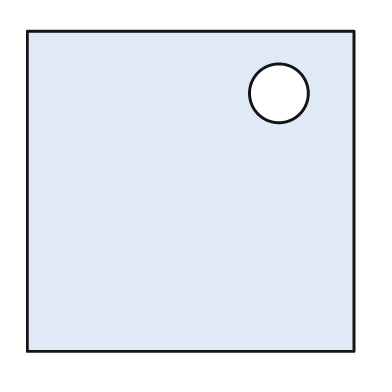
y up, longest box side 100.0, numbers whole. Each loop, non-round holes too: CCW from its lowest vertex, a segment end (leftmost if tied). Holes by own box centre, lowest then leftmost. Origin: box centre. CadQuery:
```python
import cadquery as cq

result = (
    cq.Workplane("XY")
    .moveTo(-50.0, -49.0)
    .lineTo(50.0, -49.0)
    .lineTo(50.0, 49.0)
    .lineTo(-50.0, 49.0)
    .close()
    .moveTo(27.0, 30.0)
    .circle(9.0)
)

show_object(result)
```